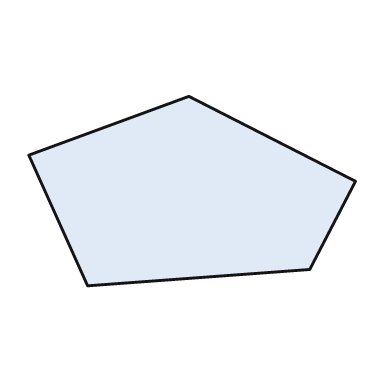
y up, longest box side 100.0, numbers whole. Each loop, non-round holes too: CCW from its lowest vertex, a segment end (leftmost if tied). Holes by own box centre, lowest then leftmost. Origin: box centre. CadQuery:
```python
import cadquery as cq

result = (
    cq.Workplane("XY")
    .moveTo(-32.0, -29.0)
    .lineTo(36.0, -24.0)
    .lineTo(50.0, 3.0)
    .lineTo(-1.0, 29.0)
    .lineTo(-50.0, 11.0)
    .close()
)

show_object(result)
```